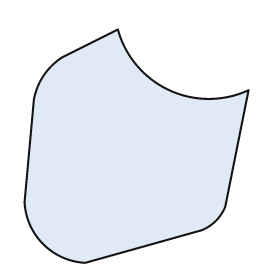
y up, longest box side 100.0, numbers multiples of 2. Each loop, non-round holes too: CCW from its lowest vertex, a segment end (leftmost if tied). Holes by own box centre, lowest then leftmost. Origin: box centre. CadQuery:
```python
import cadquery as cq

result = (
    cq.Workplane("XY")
    .moveTo(-22.0, -50.0)
    .lineTo(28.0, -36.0)
    .threePointArc((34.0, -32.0), (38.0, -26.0))
    .lineTo(48.0, 24.0)
    .threePointArc((14.0, 24.0), (-8.0, 50.0))
    .lineTo(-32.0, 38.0)
    .threePointArc((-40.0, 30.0), (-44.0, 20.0))
    .lineTo(-48.0, -24.0)
    .threePointArc((-40.0, -42.0), (-22.0, -50.0))
    .close()
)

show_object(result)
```